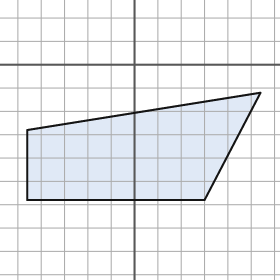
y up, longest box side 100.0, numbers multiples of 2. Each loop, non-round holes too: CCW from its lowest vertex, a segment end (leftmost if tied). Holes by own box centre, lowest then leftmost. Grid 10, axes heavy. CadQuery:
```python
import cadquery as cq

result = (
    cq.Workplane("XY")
    .moveTo(-46.0, -58.0)
    .lineTo(30.0, -58.0)
    .lineTo(54.0, -12.0)
    .lineTo(-46.0, -28.0)
    .close()
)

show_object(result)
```